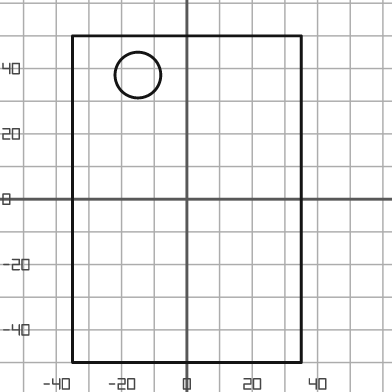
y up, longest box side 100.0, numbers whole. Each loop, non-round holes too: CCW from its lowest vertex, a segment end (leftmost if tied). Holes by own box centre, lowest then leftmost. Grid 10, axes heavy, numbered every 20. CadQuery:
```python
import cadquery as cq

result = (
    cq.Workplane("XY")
    .moveTo(-35.0, -50.0)
    .lineTo(35.0, -50.0)
    .lineTo(35.0, 50.0)
    .lineTo(-35.0, 50.0)
    .close()
    .moveTo(-15.0, 38.0)
    .circle(7.0)
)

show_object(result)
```